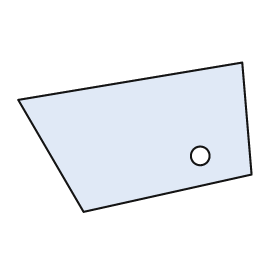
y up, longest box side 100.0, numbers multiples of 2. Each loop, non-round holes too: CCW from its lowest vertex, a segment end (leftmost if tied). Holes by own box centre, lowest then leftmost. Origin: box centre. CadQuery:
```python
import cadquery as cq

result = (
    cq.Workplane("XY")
    .moveTo(-22.0, -32.0)
    .lineTo(50.0, -16.0)
    .lineTo(46.0, 32.0)
    .lineTo(-50.0, 16.0)
    .close()
    .moveTo(28.0, -8.0)
    .circle(4.0)
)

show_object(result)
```